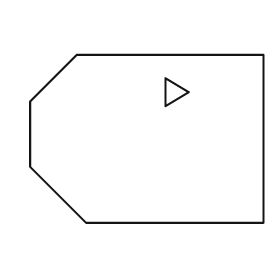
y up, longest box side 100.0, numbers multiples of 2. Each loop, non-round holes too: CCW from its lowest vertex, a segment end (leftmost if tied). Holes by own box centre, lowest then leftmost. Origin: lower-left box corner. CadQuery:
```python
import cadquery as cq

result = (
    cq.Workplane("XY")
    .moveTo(24.0, 0.0)
    .lineTo(100.0, 0.0)
    .lineTo(100.0, 72.0)
    .lineTo(20.0, 72.0)
    .lineTo(0.0, 52.0)
    .lineTo(0.0, 24.0)
    .close()
    .moveTo(58.0, 50.0)
    .lineTo(68.0, 56.0)
    .lineTo(58.0, 62.0)
    .close()
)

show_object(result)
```